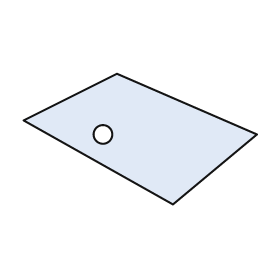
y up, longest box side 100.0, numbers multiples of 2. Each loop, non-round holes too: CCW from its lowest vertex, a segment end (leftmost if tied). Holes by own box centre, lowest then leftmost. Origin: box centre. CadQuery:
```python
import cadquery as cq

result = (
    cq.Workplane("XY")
    .moveTo(14.0, -28.0)
    .lineTo(50.0, 2.0)
    .lineTo(-10.0, 28.0)
    .lineTo(-50.0, 8.0)
    .close()
    .moveTo(-16.0, 2.0)
    .circle(4.0)
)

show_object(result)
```